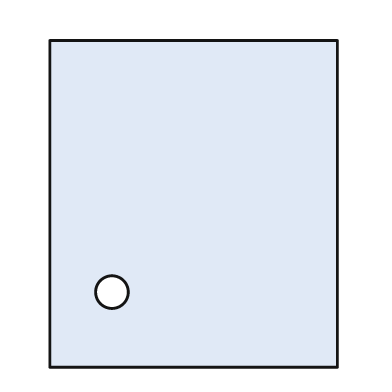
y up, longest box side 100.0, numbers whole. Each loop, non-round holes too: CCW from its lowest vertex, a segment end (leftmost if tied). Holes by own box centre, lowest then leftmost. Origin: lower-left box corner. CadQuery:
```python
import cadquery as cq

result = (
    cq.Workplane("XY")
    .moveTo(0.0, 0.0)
    .lineTo(88.0, 0.0)
    .lineTo(88.0, 100.0)
    .lineTo(0.0, 100.0)
    .close()
    .moveTo(19.0, 23.0)
    .circle(5.0)
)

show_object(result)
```